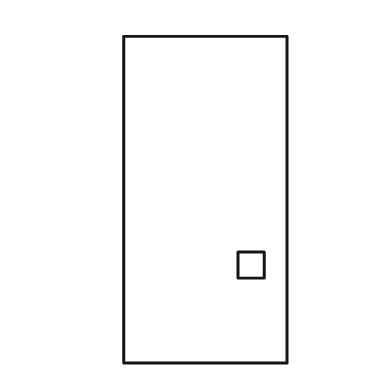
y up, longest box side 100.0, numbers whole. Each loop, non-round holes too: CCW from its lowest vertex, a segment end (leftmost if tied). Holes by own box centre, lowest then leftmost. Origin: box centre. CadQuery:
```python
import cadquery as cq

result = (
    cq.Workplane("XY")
    .moveTo(-25.0, -50.0)
    .lineTo(25.0, -50.0)
    .lineTo(25.0, 50.0)
    .lineTo(-25.0, 50.0)
    .close()
    .moveTo(10.0, -24.0)
    .lineTo(18.0, -24.0)
    .lineTo(18.0, -16.0)
    .lineTo(10.0, -16.0)
    .close()
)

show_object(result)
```